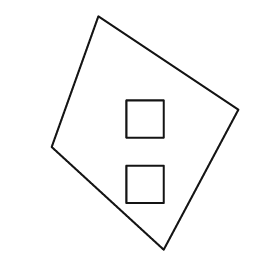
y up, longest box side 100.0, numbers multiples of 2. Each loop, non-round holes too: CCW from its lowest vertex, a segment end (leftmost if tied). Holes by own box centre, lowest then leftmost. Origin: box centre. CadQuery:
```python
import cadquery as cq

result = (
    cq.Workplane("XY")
    .moveTo(8.0, -50.0)
    .lineTo(40.0, 10.0)
    .lineTo(-20.0, 50.0)
    .lineTo(-40.0, -6.0)
    .close()
    .moveTo(-8.0, -30.0)
    .lineTo(8.0, -30.0)
    .lineTo(8.0, -14.0)
    .lineTo(-8.0, -14.0)
    .close()
    .moveTo(-8.0, -2.0)
    .lineTo(8.0, -2.0)
    .lineTo(8.0, 14.0)
    .lineTo(-8.0, 14.0)
    .close()
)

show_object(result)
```